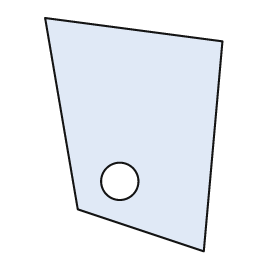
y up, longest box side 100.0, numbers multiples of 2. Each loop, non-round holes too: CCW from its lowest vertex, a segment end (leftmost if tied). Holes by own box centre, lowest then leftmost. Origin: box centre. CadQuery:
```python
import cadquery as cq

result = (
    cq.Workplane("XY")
    .moveTo(30.0, -50.0)
    .lineTo(38.0, 40.0)
    .lineTo(-38.0, 50.0)
    .lineTo(-24.0, -32.0)
    .close()
    .moveTo(-6.0, -20.0)
    .circle(8.0)
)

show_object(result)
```